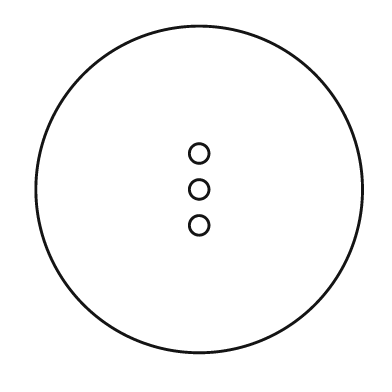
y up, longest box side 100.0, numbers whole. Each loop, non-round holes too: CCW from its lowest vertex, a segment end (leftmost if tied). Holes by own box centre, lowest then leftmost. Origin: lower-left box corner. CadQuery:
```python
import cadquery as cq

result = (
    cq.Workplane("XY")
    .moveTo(50.0, 50.0)
    .circle(50.0)
    .moveTo(50.0, 39.0)
    .circle(3.0)
    .moveTo(50.0, 50.0)
    .circle(3.0)
    .moveTo(50.0, 61.0)
    .circle(3.0)
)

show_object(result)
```